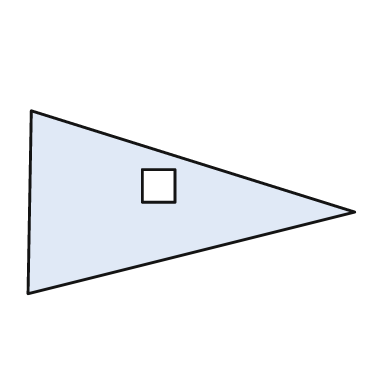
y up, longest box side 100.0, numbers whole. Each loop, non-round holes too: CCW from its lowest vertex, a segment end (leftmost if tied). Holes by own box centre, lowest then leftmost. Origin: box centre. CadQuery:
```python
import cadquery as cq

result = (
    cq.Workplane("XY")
    .moveTo(-50.0, -28.0)
    .lineTo(50.0, -3.0)
    .lineTo(-49.0, 28.0)
    .close()
    .moveTo(-15.0, 0.0)
    .lineTo(-5.0, 0.0)
    .lineTo(-5.0, 10.0)
    .lineTo(-15.0, 10.0)
    .close()
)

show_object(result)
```